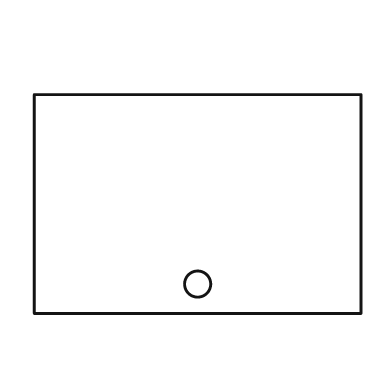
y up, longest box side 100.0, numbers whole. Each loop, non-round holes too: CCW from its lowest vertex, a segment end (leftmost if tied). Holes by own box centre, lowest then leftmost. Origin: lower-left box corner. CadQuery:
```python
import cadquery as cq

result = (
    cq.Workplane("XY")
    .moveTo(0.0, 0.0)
    .lineTo(100.0, 0.0)
    .lineTo(100.0, 67.0)
    .lineTo(0.0, 67.0)
    .close()
    .moveTo(50.0, 9.0)
    .circle(4.0)
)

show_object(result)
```